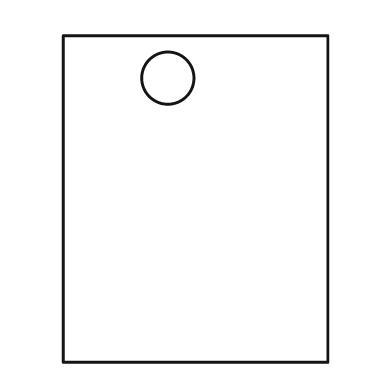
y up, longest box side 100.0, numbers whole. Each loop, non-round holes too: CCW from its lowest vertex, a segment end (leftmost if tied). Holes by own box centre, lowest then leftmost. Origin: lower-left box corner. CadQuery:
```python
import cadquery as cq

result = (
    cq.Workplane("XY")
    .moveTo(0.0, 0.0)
    .lineTo(81.0, 0.0)
    .lineTo(81.0, 100.0)
    .lineTo(0.0, 100.0)
    .close()
    .moveTo(32.0, 87.0)
    .circle(8.0)
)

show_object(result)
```